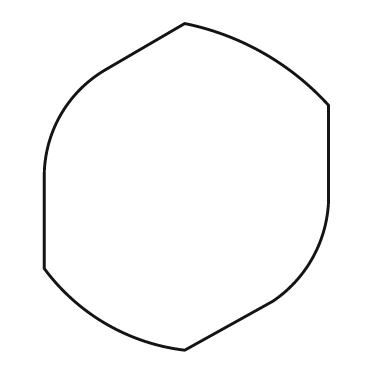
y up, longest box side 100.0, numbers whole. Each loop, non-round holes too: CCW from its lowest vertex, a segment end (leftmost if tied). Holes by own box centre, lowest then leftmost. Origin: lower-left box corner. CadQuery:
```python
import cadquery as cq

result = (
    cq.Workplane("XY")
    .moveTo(43.0, 0.0)
    .lineTo(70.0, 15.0)
    .threePointArc((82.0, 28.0), (87.0, 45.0))
    .lineTo(87.0, 75.0)
    .threePointArc((67.0, 91.0), (43.0, 100.0))
    .lineTo(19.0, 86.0)
    .threePointArc((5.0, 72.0), (0.0, 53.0))
    .lineTo(0.0, 25.0)
    .threePointArc((19.0, 8.0), (43.0, 0.0))
    .close()
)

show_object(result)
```